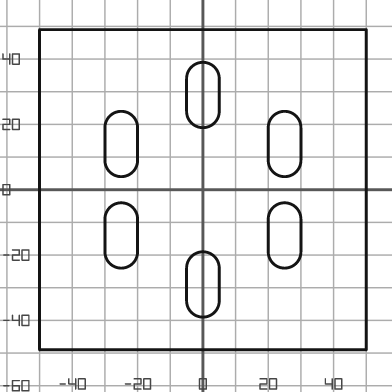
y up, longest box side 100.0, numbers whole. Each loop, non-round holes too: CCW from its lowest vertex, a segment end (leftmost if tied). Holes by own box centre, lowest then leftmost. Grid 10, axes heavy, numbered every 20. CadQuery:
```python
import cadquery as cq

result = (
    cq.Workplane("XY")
    .moveTo(-50.0, -49.0)
    .lineTo(50.0, -49.0)
    .lineTo(50.0, 49.0)
    .lineTo(-50.0, 49.0)
    .close()
    .moveTo(-5.0, -34.0)
    .threePointArc((0.0, -39.0), (5.0, -34.0))
    .lineTo(5.0, -24.0)
    .threePointArc((0.0, -19.0), (-5.0, -24.0))
    .close()
    .moveTo(-30.0, -19.0)
    .threePointArc((-25.0, -24.0), (-20.0, -19.0))
    .lineTo(-20.0, -9.0)
    .threePointArc((-25.0, -4.0), (-30.0, -9.0))
    .close()
    .moveTo(20.0, -19.0)
    .threePointArc((25.0, -24.0), (30.0, -19.0))
    .lineTo(30.0, -9.0)
    .threePointArc((25.0, -4.0), (20.0, -9.0))
    .close()
    .moveTo(-30.0, 9.0)
    .threePointArc((-25.0, 4.0), (-20.0, 9.0))
    .lineTo(-20.0, 19.0)
    .threePointArc((-25.0, 24.0), (-30.0, 19.0))
    .close()
    .moveTo(20.0, 9.0)
    .threePointArc((25.0, 4.0), (30.0, 9.0))
    .lineTo(30.0, 19.0)
    .threePointArc((25.0, 24.0), (20.0, 19.0))
    .close()
    .moveTo(-5.0, 24.0)
    .threePointArc((0.0, 19.0), (5.0, 24.0))
    .lineTo(5.0, 34.0)
    .threePointArc((0.0, 39.0), (-5.0, 34.0))
    .close()
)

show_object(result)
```